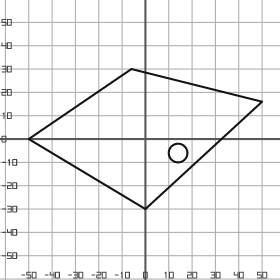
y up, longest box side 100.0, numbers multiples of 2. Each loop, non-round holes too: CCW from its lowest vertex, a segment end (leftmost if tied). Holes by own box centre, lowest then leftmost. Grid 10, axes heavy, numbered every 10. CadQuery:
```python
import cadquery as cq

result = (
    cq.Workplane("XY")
    .moveTo(0.0, -30.0)
    .lineTo(50.0, 16.0)
    .lineTo(-6.0, 30.0)
    .lineTo(-50.0, 0.0)
    .close()
    .moveTo(14.0, -6.0)
    .circle(4.0)
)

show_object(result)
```